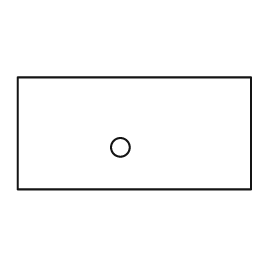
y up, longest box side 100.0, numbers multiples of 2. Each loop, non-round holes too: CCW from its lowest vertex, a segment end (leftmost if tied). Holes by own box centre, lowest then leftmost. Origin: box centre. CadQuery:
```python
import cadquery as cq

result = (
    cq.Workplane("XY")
    .moveTo(-50.0, -24.0)
    .lineTo(50.0, -24.0)
    .lineTo(50.0, 24.0)
    .lineTo(-50.0, 24.0)
    .close()
    .moveTo(-6.0, -6.0)
    .circle(4.0)
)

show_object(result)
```